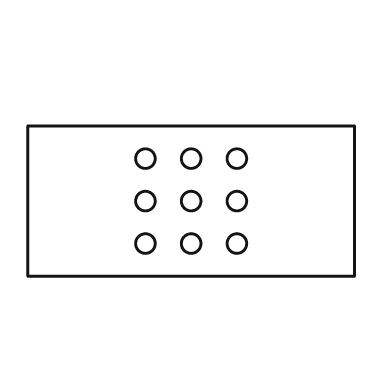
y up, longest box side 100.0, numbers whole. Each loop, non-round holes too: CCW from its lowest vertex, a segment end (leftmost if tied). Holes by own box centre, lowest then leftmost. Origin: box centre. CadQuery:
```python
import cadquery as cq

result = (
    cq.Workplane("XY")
    .moveTo(-50.0, -23.0)
    .lineTo(50.0, -23.0)
    .lineTo(50.0, 23.0)
    .lineTo(-50.0, 23.0)
    .close()
    .moveTo(-14.0, -13.0)
    .circle(3.0)
    .moveTo(0.0, -13.0)
    .circle(3.0)
    .moveTo(14.0, -13.0)
    .circle(3.0)
    .moveTo(-14.0, 0.0)
    .circle(3.0)
    .moveTo(0.0, 0.0)
    .circle(3.0)
    .moveTo(14.0, 0.0)
    .circle(3.0)
    .moveTo(-14.0, 13.0)
    .circle(3.0)
    .moveTo(0.0, 13.0)
    .circle(3.0)
    .moveTo(14.0, 13.0)
    .circle(3.0)
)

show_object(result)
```